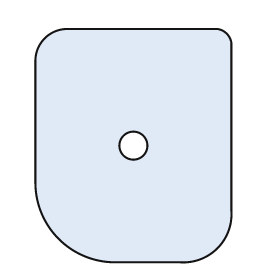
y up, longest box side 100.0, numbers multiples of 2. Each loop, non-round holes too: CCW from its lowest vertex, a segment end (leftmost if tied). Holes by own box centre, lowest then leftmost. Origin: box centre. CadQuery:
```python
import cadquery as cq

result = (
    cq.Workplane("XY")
    .moveTo(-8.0, -50.0)
    .lineTo(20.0, -50.0)
    .threePointArc((36.0, -44.0), (42.0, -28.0))
    .lineTo(42.0, 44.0)
    .threePointArc((40.0, 48.0), (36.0, 50.0))
    .lineTo(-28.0, 50.0)
    .threePointArc((-38.0, 46.0), (-42.0, 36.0))
    .lineTo(-42.0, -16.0)
    .threePointArc((-32.0, -40.0), (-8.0, -50.0))
    .close()
    .moveTo(0.0, 0.0)
    .circle(6.0)
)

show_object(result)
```